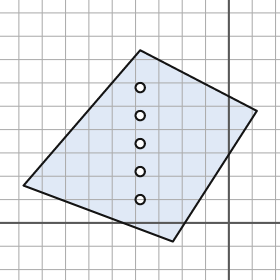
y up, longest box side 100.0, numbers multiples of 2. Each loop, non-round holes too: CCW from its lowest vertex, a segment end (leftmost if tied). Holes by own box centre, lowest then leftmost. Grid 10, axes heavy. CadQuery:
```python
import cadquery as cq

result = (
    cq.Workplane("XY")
    .moveTo(-24.0, -8.0)
    .lineTo(12.0, 48.0)
    .lineTo(-38.0, 74.0)
    .lineTo(-88.0, 16.0)
    .close()
    .moveTo(-38.0, 10.0)
    .circle(2.0)
    .moveTo(-38.0, 22.0)
    .circle(2.0)
    .moveTo(-38.0, 34.0)
    .circle(2.0)
    .moveTo(-38.0, 46.0)
    .circle(2.0)
    .moveTo(-38.0, 58.0)
    .circle(2.0)
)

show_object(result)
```